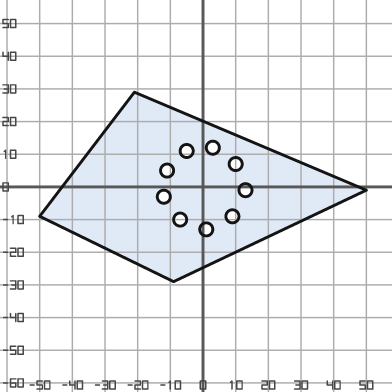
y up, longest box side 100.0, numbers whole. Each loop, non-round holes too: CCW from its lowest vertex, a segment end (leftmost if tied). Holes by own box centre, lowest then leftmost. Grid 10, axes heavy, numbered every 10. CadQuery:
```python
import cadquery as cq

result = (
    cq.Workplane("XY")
    .moveTo(-9.0, -29.0)
    .lineTo(50.0, -1.0)
    .lineTo(-21.0, 29.0)
    .lineTo(-50.0, -9.0)
    .close()
    .moveTo(1.0, -13.0)
    .circle(2.0)
    .moveTo(-7.0, -10.0)
    .circle(2.0)
    .moveTo(9.0, -9.0)
    .circle(2.0)
    .moveTo(-12.0, -3.0)
    .circle(2.0)
    .moveTo(13.0, -1.0)
    .circle(2.0)
    .moveTo(-11.0, 5.0)
    .circle(2.0)
    .moveTo(10.0, 7.0)
    .circle(2.0)
    .moveTo(-5.0, 11.0)
    .circle(2.0)
    .moveTo(3.0, 12.0)
    .circle(2.0)
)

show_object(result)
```